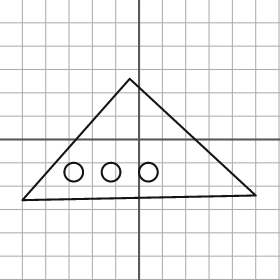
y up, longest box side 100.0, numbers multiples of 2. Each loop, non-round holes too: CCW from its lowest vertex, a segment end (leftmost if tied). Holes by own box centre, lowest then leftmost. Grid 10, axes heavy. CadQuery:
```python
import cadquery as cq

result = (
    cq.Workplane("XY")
    .moveTo(-50.0, -26.0)
    .lineTo(50.0, -24.0)
    .lineTo(-4.0, 26.0)
    .close()
    .moveTo(-28.0, -14.0)
    .circle(4.0)
    .moveTo(-12.0, -14.0)
    .circle(4.0)
    .moveTo(4.0, -14.0)
    .circle(4.0)
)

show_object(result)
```